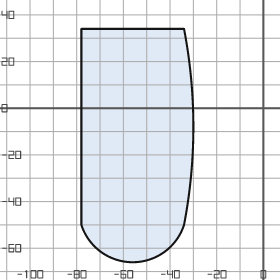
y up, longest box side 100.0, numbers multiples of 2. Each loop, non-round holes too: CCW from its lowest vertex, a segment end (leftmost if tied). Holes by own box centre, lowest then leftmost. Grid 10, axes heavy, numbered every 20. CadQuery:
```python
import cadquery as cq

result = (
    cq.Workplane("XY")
    .moveTo(-78.0, -50.0)
    .threePointArc((-56.0, -66.0), (-34.0, -50.0))
    .threePointArc((-30.0, -8.0), (-34.0, 34.0))
    .lineTo(-78.0, 34.0)
    .close()
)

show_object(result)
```